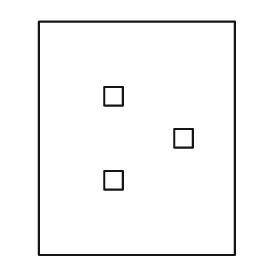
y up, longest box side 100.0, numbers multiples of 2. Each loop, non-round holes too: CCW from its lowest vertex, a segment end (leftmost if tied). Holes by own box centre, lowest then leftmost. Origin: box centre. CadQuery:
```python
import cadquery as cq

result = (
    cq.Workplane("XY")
    .moveTo(-42.0, -50.0)
    .lineTo(42.0, -50.0)
    .lineTo(42.0, 50.0)
    .lineTo(-42.0, 50.0)
    .close()
    .moveTo(-14.0, -22.0)
    .lineTo(-6.0, -22.0)
    .lineTo(-6.0, -14.0)
    .lineTo(-14.0, -14.0)
    .close()
    .moveTo(16.0, -4.0)
    .lineTo(24.0, -4.0)
    .lineTo(24.0, 4.0)
    .lineTo(16.0, 4.0)
    .close()
    .moveTo(-14.0, 14.0)
    .lineTo(-6.0, 14.0)
    .lineTo(-6.0, 22.0)
    .lineTo(-14.0, 22.0)
    .close()
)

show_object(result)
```